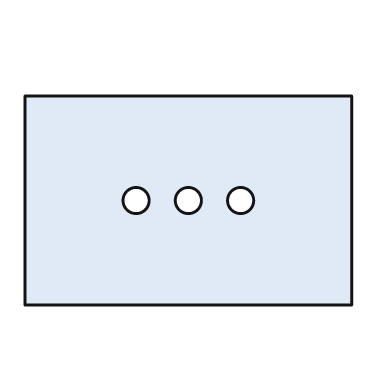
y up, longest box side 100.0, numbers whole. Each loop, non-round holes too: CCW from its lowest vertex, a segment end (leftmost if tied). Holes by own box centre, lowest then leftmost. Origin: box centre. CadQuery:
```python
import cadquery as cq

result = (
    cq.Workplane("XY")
    .moveTo(-50.0, -32.0)
    .lineTo(50.0, -32.0)
    .lineTo(50.0, 32.0)
    .lineTo(-50.0, 32.0)
    .close()
    .moveTo(-16.0, 0.0)
    .circle(4.0)
    .moveTo(0.0, 0.0)
    .circle(4.0)
    .moveTo(16.0, 0.0)
    .circle(4.0)
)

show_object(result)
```